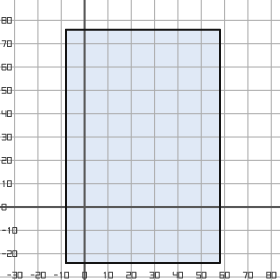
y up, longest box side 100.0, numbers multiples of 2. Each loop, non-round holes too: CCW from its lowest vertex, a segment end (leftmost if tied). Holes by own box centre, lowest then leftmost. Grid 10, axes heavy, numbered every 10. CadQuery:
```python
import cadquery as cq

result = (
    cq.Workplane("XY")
    .moveTo(-8.0, -24.0)
    .lineTo(58.0, -24.0)
    .lineTo(58.0, 76.0)
    .lineTo(-8.0, 76.0)
    .close()
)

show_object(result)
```